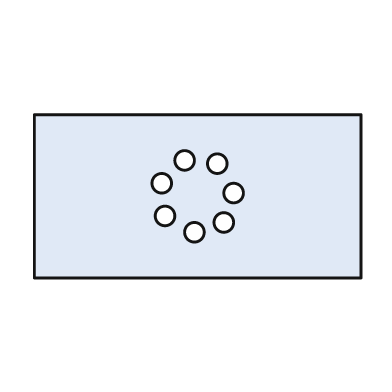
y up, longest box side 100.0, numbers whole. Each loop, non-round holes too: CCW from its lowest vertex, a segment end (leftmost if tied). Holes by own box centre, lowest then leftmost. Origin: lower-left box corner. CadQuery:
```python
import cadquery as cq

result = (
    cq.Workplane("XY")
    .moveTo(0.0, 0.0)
    .lineTo(100.0, 0.0)
    .lineTo(100.0, 50.0)
    .lineTo(0.0, 50.0)
    .close()
    .moveTo(49.0, 14.0)
    .circle(3.0)
    .moveTo(58.0, 17.0)
    .circle(3.0)
    .moveTo(40.0, 19.0)
    .circle(3.0)
    .moveTo(61.0, 26.0)
    .circle(3.0)
    .moveTo(39.0, 29.0)
    .circle(3.0)
    .moveTo(56.0, 35.0)
    .circle(3.0)
    .moveTo(46.0, 36.0)
    .circle(3.0)
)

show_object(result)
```